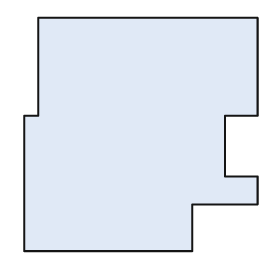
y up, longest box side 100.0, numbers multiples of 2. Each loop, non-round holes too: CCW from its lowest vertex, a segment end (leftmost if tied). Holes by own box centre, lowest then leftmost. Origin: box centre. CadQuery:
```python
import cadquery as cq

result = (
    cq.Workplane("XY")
    .moveTo(-50.0, -50.0)
    .lineTo(22.0, -50.0)
    .lineTo(22.0, -30.0)
    .lineTo(50.0, -30.0)
    .lineTo(50.0, -18.0)
    .lineTo(36.0, -18.0)
    .lineTo(36.0, 8.0)
    .lineTo(50.0, 8.0)
    .lineTo(50.0, 50.0)
    .lineTo(-44.0, 50.0)
    .lineTo(-44.0, 8.0)
    .lineTo(-50.0, 8.0)
    .close()
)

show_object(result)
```